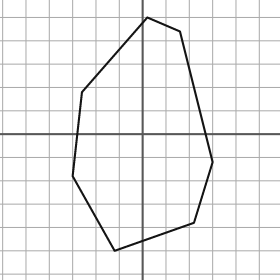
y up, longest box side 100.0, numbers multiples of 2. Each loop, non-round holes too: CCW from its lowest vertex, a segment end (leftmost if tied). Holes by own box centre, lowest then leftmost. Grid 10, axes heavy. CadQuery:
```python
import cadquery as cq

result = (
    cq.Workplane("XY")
    .moveTo(-12.0, -50.0)
    .lineTo(22.0, -38.0)
    .lineTo(30.0, -12.0)
    .lineTo(16.0, 44.0)
    .lineTo(2.0, 50.0)
    .lineTo(-26.0, 18.0)
    .lineTo(-30.0, -18.0)
    .close()
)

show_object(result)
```